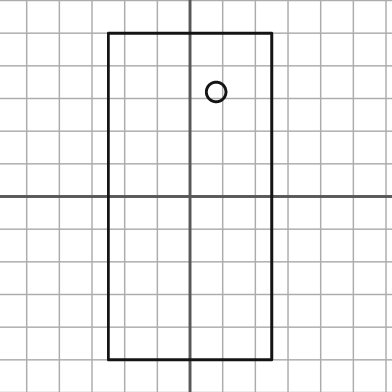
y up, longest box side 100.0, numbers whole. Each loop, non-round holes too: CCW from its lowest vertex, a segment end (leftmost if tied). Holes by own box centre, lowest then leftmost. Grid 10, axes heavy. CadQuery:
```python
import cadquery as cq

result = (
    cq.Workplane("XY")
    .moveTo(-25.0, -50.0)
    .lineTo(25.0, -50.0)
    .lineTo(25.0, 50.0)
    .lineTo(-25.0, 50.0)
    .close()
    .moveTo(8.0, 32.0)
    .circle(3.0)
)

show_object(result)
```